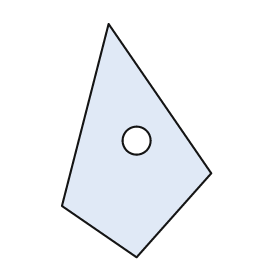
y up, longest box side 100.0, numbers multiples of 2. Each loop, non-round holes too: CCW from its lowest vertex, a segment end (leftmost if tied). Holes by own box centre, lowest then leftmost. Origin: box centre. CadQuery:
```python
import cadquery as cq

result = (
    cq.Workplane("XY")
    .moveTo(0.0, -50.0)
    .lineTo(32.0, -14.0)
    .lineTo(-12.0, 50.0)
    .lineTo(-32.0, -28.0)
    .close()
    .moveTo(0.0, 0.0)
    .circle(6.0)
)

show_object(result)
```